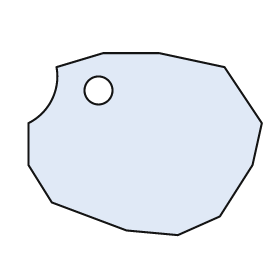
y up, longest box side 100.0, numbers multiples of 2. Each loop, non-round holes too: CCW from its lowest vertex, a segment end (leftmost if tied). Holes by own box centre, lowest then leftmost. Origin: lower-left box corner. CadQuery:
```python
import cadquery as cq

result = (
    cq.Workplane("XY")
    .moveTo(64.0, 0.0)
    .lineTo(82.0, 8.0)
    .lineTo(96.0, 30.0)
    .lineTo(100.0, 48.0)
    .lineTo(84.0, 72.0)
    .lineTo(56.0, 78.0)
    .lineTo(32.0, 78.0)
    .lineTo(12.0, 72.0)
    .threePointArc((10.0, 58.0), (0.0, 48.0))
    .lineTo(0.0, 30.0)
    .lineTo(10.0, 14.0)
    .lineTo(42.0, 2.0)
    .close()
    .moveTo(30.0, 62.0)
    .circle(6.0)
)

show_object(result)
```